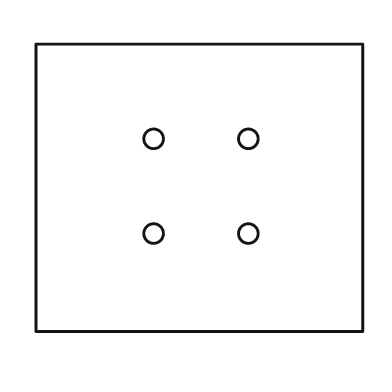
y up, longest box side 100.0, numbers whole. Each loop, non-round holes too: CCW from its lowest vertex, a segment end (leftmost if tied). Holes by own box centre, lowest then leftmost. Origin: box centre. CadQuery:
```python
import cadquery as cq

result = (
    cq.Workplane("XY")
    .moveTo(-50.0, -44.0)
    .lineTo(50.0, -44.0)
    .lineTo(50.0, 44.0)
    .lineTo(-50.0, 44.0)
    .close()
    .moveTo(-14.0, -14.0)
    .circle(3.0)
    .moveTo(15.0, -14.0)
    .circle(3.0)
    .moveTo(-14.0, 15.0)
    .circle(3.0)
    .moveTo(15.0, 15.0)
    .circle(3.0)
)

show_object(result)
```